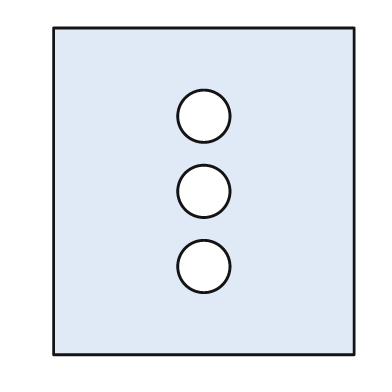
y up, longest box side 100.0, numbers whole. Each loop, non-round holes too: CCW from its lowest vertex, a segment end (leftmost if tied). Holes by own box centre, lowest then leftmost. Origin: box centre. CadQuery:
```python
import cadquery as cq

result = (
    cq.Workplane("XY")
    .moveTo(-46.0, -50.0)
    .lineTo(46.0, -50.0)
    .lineTo(46.0, 50.0)
    .lineTo(-46.0, 50.0)
    .close()
    .moveTo(0.0, -23.0)
    .circle(8.0)
    .moveTo(0.0, 0.0)
    .circle(8.0)
    .moveTo(0.0, 23.0)
    .circle(8.0)
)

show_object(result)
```